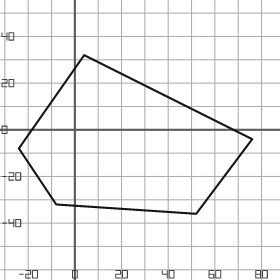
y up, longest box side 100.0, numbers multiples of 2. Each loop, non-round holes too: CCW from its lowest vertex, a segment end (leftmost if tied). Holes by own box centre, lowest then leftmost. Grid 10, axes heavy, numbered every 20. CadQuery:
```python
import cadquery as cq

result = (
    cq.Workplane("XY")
    .moveTo(52.0, -36.0)
    .lineTo(76.0, -4.0)
    .lineTo(4.0, 32.0)
    .lineTo(-24.0, -8.0)
    .lineTo(-8.0, -32.0)
    .close()
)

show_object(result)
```